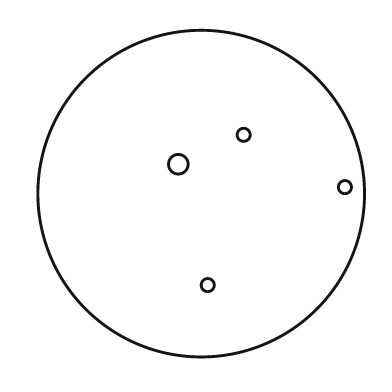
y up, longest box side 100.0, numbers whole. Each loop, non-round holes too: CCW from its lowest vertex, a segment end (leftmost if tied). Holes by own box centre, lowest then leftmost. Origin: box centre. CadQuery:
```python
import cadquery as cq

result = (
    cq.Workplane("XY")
    .moveTo(0.0, 0.0)
    .circle(50.0)
    .moveTo(2.0, -28.0)
    .circle(2.0)
    .moveTo(44.0, 2.0)
    .circle(2.0)
    .moveTo(-7.0, 9.0)
    .circle(3.0)
    .moveTo(13.0, 18.0)
    .circle(2.0)
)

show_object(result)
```